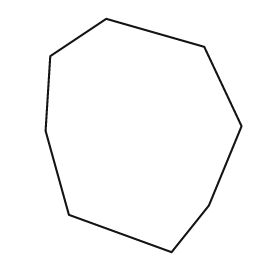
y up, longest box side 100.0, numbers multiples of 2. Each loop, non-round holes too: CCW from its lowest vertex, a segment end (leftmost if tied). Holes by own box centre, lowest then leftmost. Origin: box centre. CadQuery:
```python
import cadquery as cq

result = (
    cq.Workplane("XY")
    .moveTo(12.0, -50.0)
    .lineTo(28.0, -30.0)
    .lineTo(42.0, 4.0)
    .lineTo(26.0, 38.0)
    .lineTo(-16.0, 50.0)
    .lineTo(-40.0, 34.0)
    .lineTo(-42.0, 2.0)
    .lineTo(-32.0, -34.0)
    .close()
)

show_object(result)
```